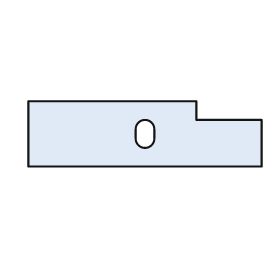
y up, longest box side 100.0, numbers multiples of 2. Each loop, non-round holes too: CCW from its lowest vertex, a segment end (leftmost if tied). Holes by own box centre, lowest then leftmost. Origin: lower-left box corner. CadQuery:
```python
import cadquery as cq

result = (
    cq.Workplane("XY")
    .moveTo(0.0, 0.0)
    .lineTo(100.0, 0.0)
    .lineTo(100.0, 20.0)
    .lineTo(72.0, 20.0)
    .lineTo(72.0, 28.0)
    .lineTo(0.0, 28.0)
    .close()
    .moveTo(46.0, 12.0)
    .threePointArc((50.0, 8.0), (54.0, 12.0))
    .lineTo(54.0, 16.0)
    .threePointArc((50.0, 20.0), (46.0, 16.0))
    .close()
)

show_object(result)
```